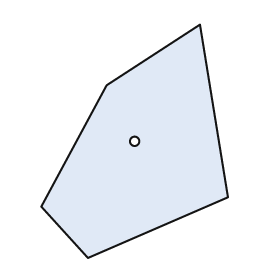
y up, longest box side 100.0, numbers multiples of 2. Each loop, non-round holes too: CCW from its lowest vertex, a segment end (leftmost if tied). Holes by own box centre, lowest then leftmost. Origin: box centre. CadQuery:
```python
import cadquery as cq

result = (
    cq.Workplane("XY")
    .moveTo(-20.0, -50.0)
    .lineTo(40.0, -24.0)
    .lineTo(28.0, 50.0)
    .lineTo(-12.0, 24.0)
    .lineTo(-40.0, -28.0)
    .close()
    .moveTo(0.0, 0.0)
    .circle(2.0)
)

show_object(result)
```